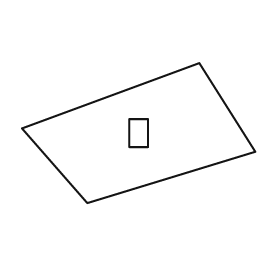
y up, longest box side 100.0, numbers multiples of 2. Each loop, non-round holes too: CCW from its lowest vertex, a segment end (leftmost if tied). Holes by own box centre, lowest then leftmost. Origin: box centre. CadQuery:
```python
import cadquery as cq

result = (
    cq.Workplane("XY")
    .moveTo(-22.0, -30.0)
    .lineTo(50.0, -8.0)
    .lineTo(26.0, 30.0)
    .lineTo(-50.0, 2.0)
    .close()
    .moveTo(-4.0, -6.0)
    .lineTo(4.0, -6.0)
    .lineTo(4.0, 6.0)
    .lineTo(-4.0, 6.0)
    .close()
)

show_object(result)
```